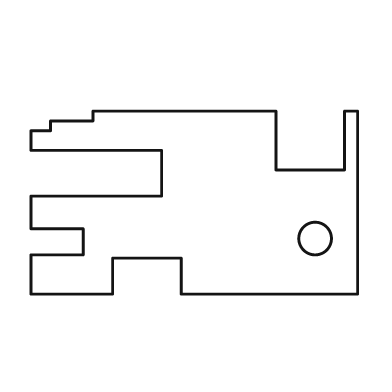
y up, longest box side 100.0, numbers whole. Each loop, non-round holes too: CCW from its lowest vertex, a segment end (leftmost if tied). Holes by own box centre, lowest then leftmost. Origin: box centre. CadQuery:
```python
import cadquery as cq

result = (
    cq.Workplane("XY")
    .moveTo(-50.0, -28.0)
    .lineTo(-25.0, -28.0)
    .lineTo(-25.0, -17.0)
    .lineTo(-4.0, -17.0)
    .lineTo(-4.0, -28.0)
    .lineTo(50.0, -28.0)
    .lineTo(50.0, 28.0)
    .lineTo(46.0, 28.0)
    .lineTo(46.0, 10.0)
    .lineTo(25.0, 10.0)
    .lineTo(25.0, 28.0)
    .lineTo(-31.0, 28.0)
    .lineTo(-31.0, 25.0)
    .lineTo(-44.0, 25.0)
    .lineTo(-44.0, 22.0)
    .lineTo(-50.0, 22.0)
    .lineTo(-50.0, 16.0)
    .lineTo(-10.0, 16.0)
    .lineTo(-10.0, 2.0)
    .lineTo(-50.0, 2.0)
    .lineTo(-50.0, -8.0)
    .lineTo(-34.0, -8.0)
    .lineTo(-34.0, -16.0)
    .lineTo(-50.0, -16.0)
    .close()
    .moveTo(37.0, -11.0)
    .circle(5.0)
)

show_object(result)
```